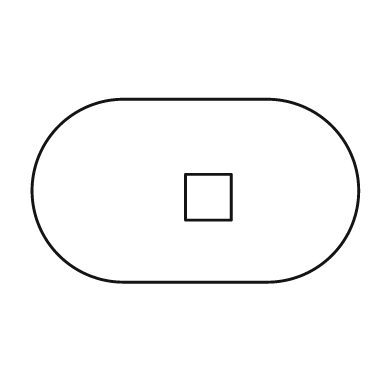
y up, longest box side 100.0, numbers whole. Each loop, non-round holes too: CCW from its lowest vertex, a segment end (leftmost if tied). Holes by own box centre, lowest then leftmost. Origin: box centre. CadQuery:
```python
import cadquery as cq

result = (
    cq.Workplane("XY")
    .moveTo(-22.0, -28.0)
    .lineTo(22.0, -28.0)
    .threePointArc((50.0, 0.0), (22.0, 28.0))
    .lineTo(-22.0, 28.0)
    .threePointArc((-50.0, 0.0), (-22.0, -28.0))
    .close()
    .moveTo(-3.0, -9.0)
    .lineTo(11.0, -9.0)
    .lineTo(11.0, 5.0)
    .lineTo(-3.0, 5.0)
    .close()
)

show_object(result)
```